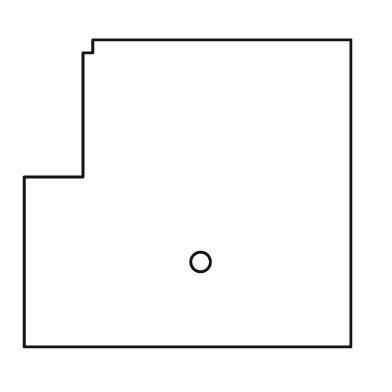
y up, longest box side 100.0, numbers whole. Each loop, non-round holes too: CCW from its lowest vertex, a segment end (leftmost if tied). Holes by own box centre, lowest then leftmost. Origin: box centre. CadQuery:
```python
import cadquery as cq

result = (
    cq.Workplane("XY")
    .moveTo(-50.0, -47.0)
    .lineTo(50.0, -47.0)
    .lineTo(50.0, 47.0)
    .lineTo(-29.0, 47.0)
    .lineTo(-29.0, 43.0)
    .lineTo(-32.0, 43.0)
    .lineTo(-32.0, 5.0)
    .lineTo(-50.0, 5.0)
    .close()
    .moveTo(4.0, -21.0)
    .circle(3.0)
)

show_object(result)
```